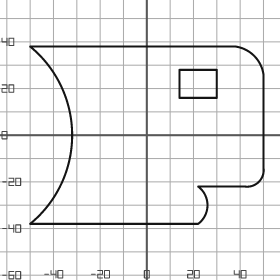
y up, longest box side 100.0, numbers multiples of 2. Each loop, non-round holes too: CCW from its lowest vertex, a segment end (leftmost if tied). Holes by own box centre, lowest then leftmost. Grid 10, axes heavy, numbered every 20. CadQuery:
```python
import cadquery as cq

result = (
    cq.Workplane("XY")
    .moveTo(-50.0, -38.0)
    .lineTo(22.0, -38.0)
    .threePointArc((26.0, -30.0), (22.0, -22.0))
    .lineTo(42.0, -22.0)
    .threePointArc((48.0, -20.0), (50.0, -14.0))
    .lineTo(50.0, 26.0)
    .threePointArc((46.0, 34.0), (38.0, 38.0))
    .lineTo(-50.0, 38.0)
    .threePointArc((-32.0, 0.0), (-50.0, -38.0))
    .close()
    .moveTo(14.0, 16.0)
    .lineTo(30.0, 16.0)
    .lineTo(30.0, 28.0)
    .lineTo(14.0, 28.0)
    .close()
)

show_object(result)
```